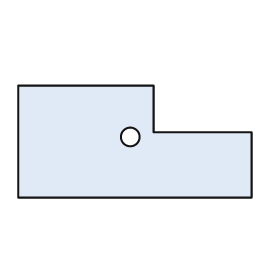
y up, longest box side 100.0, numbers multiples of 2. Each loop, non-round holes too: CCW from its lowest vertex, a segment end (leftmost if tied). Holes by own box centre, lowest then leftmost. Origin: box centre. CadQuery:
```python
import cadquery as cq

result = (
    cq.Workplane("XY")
    .moveTo(-50.0, -24.0)
    .lineTo(50.0, -24.0)
    .lineTo(50.0, 4.0)
    .lineTo(8.0, 4.0)
    .lineTo(8.0, 24.0)
    .lineTo(-50.0, 24.0)
    .close()
    .moveTo(-2.0, 2.0)
    .circle(4.0)
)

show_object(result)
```